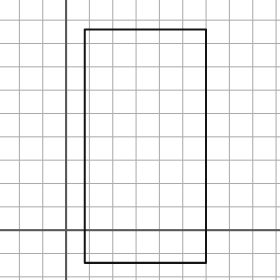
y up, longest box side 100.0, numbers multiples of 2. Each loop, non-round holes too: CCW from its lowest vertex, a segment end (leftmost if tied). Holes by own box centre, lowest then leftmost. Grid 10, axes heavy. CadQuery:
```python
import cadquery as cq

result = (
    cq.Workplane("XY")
    .moveTo(8.0, -14.0)
    .lineTo(60.0, -14.0)
    .lineTo(60.0, 86.0)
    .lineTo(8.0, 86.0)
    .close()
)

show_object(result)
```